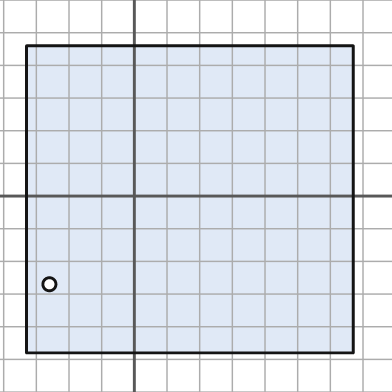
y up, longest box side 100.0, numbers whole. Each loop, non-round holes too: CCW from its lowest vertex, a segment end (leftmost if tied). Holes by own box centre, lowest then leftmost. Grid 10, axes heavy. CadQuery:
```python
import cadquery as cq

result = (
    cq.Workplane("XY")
    .moveTo(-33.0, -48.0)
    .lineTo(67.0, -48.0)
    .lineTo(67.0, 46.0)
    .lineTo(-33.0, 46.0)
    .close()
    .moveTo(-26.0, -27.0)
    .circle(2.0)
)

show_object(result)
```